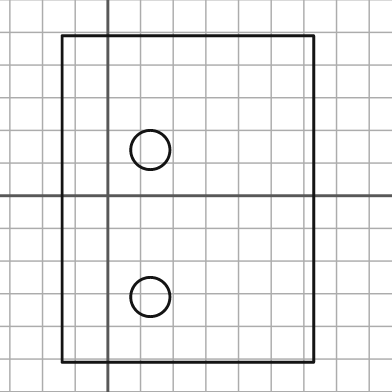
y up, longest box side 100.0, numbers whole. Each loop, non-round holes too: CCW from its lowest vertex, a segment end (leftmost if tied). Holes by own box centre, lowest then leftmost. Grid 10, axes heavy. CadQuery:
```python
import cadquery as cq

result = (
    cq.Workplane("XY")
    .moveTo(-14.0, -51.0)
    .lineTo(63.0, -51.0)
    .lineTo(63.0, 49.0)
    .lineTo(-14.0, 49.0)
    .close()
    .moveTo(13.0, -31.0)
    .circle(6.0)
    .moveTo(13.0, 14.0)
    .circle(6.0)
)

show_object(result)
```